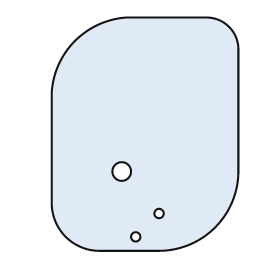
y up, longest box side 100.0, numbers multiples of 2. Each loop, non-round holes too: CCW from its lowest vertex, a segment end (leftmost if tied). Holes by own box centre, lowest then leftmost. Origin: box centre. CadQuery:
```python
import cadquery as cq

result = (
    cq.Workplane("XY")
    .moveTo(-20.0, -50.0)
    .lineTo(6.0, -50.0)
    .threePointArc((30.0, -40.0), (40.0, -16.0))
    .lineTo(40.0, 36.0)
    .threePointArc((36.0, 46.0), (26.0, 50.0))
    .lineTo(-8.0, 50.0)
    .threePointArc((-30.0, 40.0), (-40.0, 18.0))
    .lineTo(-40.0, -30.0)
    .threePointArc((-34.0, -44.0), (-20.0, -50.0))
    .close()
    .moveTo(-4.0, -44.0)
    .circle(2.0)
    .moveTo(6.0, -34.0)
    .circle(2.0)
    .moveTo(-10.0, -16.0)
    .circle(4.0)
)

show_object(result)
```